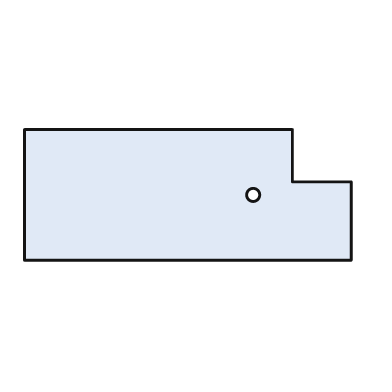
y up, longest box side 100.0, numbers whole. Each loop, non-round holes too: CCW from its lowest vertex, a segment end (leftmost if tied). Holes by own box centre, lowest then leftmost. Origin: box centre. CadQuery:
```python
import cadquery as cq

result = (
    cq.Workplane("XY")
    .moveTo(-50.0, -20.0)
    .lineTo(50.0, -20.0)
    .lineTo(50.0, 4.0)
    .lineTo(32.0, 4.0)
    .lineTo(32.0, 20.0)
    .lineTo(-50.0, 20.0)
    .close()
    .moveTo(20.0, 0.0)
    .circle(2.0)
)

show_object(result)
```